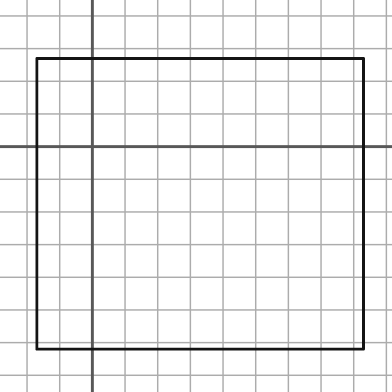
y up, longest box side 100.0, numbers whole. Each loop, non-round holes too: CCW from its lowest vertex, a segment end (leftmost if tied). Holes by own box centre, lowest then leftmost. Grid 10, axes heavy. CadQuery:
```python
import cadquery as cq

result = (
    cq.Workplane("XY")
    .moveTo(-17.0, -62.0)
    .lineTo(83.0, -62.0)
    .lineTo(83.0, 27.0)
    .lineTo(-17.0, 27.0)
    .close()
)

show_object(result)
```